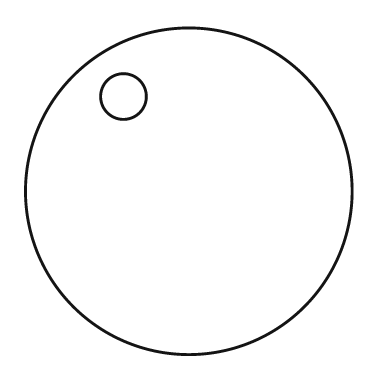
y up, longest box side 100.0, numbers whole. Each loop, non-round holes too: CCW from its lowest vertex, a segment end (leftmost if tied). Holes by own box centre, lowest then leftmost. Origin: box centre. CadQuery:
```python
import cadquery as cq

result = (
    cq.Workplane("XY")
    .moveTo(0.0, 0.0)
    .circle(50.0)
    .moveTo(-20.0, 29.0)
    .circle(7.0)
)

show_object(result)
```